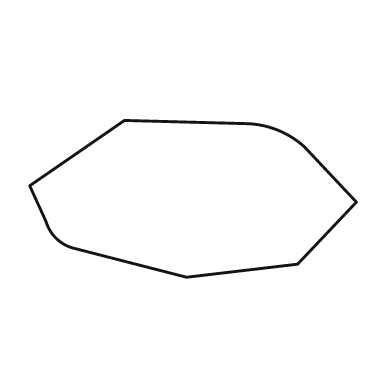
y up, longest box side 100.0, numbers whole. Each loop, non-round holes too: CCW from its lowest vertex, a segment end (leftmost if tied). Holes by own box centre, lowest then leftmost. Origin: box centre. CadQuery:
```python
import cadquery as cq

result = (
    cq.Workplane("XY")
    .moveTo(-2.0, -24.0)
    .lineTo(32.0, -20.0)
    .lineTo(50.0, -1.0)
    .lineTo(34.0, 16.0)
    .threePointArc((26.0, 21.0), (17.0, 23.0))
    .lineTo(-21.0, 24.0)
    .lineTo(-50.0, 4.0)
    .lineTo(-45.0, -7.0)
    .threePointArc((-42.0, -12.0), (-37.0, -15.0))
    .close()
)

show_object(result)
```